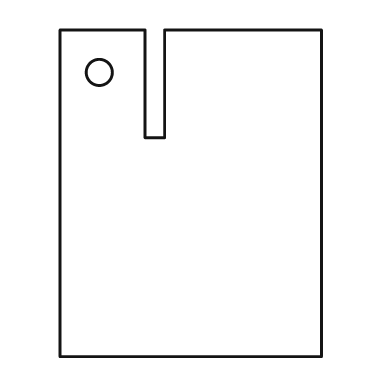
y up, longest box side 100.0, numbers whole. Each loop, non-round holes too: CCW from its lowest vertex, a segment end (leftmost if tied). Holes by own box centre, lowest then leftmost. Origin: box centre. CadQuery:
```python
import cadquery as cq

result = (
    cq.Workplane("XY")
    .moveTo(-40.0, -50.0)
    .lineTo(40.0, -50.0)
    .lineTo(40.0, 50.0)
    .lineTo(-8.0, 50.0)
    .lineTo(-8.0, 17.0)
    .lineTo(-14.0, 17.0)
    .lineTo(-14.0, 50.0)
    .lineTo(-40.0, 50.0)
    .close()
    .moveTo(-28.0, 37.0)
    .circle(4.0)
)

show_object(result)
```